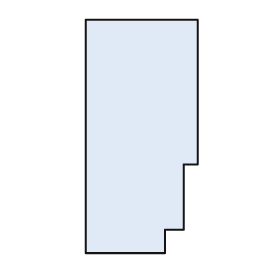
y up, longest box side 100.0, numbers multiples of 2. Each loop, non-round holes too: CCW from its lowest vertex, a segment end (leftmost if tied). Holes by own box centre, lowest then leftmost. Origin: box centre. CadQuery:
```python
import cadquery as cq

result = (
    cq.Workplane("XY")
    .moveTo(-24.0, -50.0)
    .lineTo(10.0, -50.0)
    .lineTo(10.0, -40.0)
    .lineTo(18.0, -40.0)
    .lineTo(18.0, -12.0)
    .lineTo(24.0, -12.0)
    .lineTo(24.0, 50.0)
    .lineTo(-24.0, 50.0)
    .close()
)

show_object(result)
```